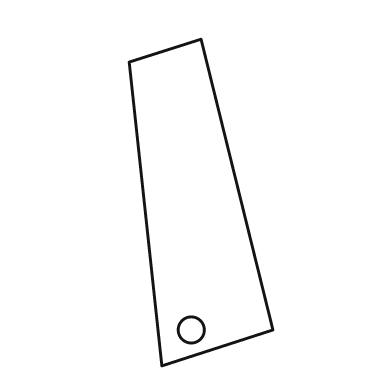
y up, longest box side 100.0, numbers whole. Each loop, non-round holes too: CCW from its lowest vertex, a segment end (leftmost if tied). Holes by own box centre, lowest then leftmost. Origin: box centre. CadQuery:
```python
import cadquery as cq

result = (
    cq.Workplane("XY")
    .moveTo(-12.0, -50.0)
    .lineTo(22.0, -39.0)
    .lineTo(0.0, 50.0)
    .lineTo(-22.0, 43.0)
    .close()
    .moveTo(-3.0, -39.0)
    .circle(4.0)
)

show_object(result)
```